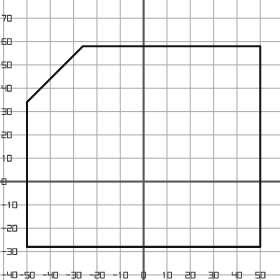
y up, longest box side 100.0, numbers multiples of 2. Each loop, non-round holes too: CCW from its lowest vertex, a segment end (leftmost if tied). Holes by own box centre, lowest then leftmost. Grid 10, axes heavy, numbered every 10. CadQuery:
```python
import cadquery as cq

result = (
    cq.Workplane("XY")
    .moveTo(-50.0, -28.0)
    .lineTo(50.0, -28.0)
    .lineTo(50.0, 58.0)
    .lineTo(-26.0, 58.0)
    .lineTo(-50.0, 34.0)
    .close()
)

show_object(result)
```